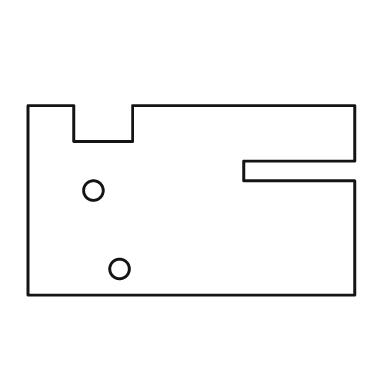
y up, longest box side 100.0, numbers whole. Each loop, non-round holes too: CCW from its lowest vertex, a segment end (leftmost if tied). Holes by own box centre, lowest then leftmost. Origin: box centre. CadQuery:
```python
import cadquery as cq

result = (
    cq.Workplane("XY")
    .moveTo(-50.0, -29.0)
    .lineTo(50.0, -29.0)
    .lineTo(50.0, 6.0)
    .lineTo(16.0, 6.0)
    .lineTo(16.0, 12.0)
    .lineTo(50.0, 12.0)
    .lineTo(50.0, 29.0)
    .lineTo(-18.0, 29.0)
    .lineTo(-18.0, 18.0)
    .lineTo(-36.0, 18.0)
    .lineTo(-36.0, 29.0)
    .lineTo(-50.0, 29.0)
    .close()
    .moveTo(-22.0, -21.0)
    .circle(3.0)
    .moveTo(-30.0, 3.0)
    .circle(3.0)
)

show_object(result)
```